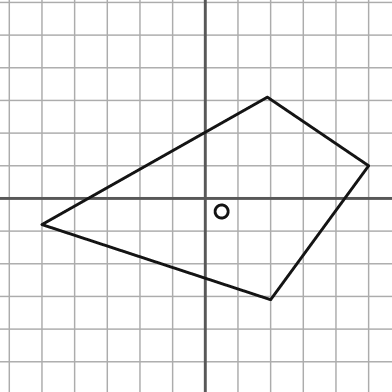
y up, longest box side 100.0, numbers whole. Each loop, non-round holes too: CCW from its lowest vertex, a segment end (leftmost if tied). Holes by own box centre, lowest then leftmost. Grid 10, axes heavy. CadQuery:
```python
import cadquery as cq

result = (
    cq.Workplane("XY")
    .moveTo(20.0, -31.0)
    .lineTo(50.0, 10.0)
    .lineTo(19.0, 31.0)
    .lineTo(-50.0, -8.0)
    .close()
    .moveTo(5.0, -4.0)
    .circle(2.0)
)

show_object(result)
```